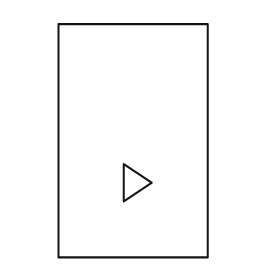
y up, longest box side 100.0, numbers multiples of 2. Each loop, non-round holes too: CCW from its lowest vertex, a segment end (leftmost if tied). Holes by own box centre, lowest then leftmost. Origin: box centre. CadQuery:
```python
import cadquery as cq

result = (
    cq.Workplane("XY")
    .moveTo(-32.0, -50.0)
    .lineTo(32.0, -50.0)
    .lineTo(32.0, 50.0)
    .lineTo(-32.0, 50.0)
    .close()
    .moveTo(-4.0, -26.0)
    .lineTo(8.0, -18.0)
    .lineTo(-4.0, -10.0)
    .close()
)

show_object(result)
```